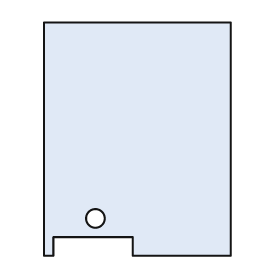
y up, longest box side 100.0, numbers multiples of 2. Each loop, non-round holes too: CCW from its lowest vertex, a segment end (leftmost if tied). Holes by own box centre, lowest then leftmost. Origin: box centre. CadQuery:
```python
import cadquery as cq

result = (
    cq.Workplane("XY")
    .moveTo(-40.0, -50.0)
    .lineTo(-36.0, -50.0)
    .lineTo(-36.0, -42.0)
    .lineTo(-2.0, -42.0)
    .lineTo(-2.0, -50.0)
    .lineTo(40.0, -50.0)
    .lineTo(40.0, 50.0)
    .lineTo(-40.0, 50.0)
    .close()
    .moveTo(-18.0, -34.0)
    .circle(4.0)
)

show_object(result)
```